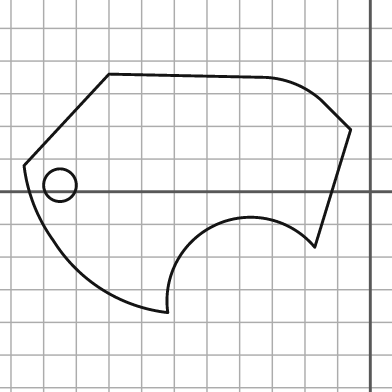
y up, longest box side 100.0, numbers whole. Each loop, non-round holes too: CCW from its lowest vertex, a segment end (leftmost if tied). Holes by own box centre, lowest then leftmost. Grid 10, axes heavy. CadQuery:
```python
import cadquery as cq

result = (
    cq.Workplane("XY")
    .moveTo(-62.0, -37.0)
    .threePointArc((-47.0, -10.0), (-17.0, -17.0))
    .lineTo(-6.0, 19.0)
    .lineTo(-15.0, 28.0)
    .threePointArc((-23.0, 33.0), (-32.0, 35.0))
    .lineTo(-80.0, 36.0)
    .lineTo(-106.0, 8.0)
    .threePointArc((-103.0, -4.0), (-97.0, -15.0))
    .threePointArc((-82.0, -30.0), (-62.0, -37.0))
    .close()
    .moveTo(-95.0, 2.0)
    .circle(5.0)
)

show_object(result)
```